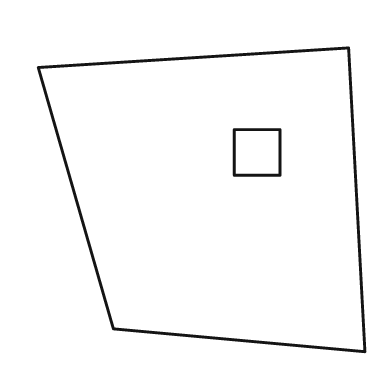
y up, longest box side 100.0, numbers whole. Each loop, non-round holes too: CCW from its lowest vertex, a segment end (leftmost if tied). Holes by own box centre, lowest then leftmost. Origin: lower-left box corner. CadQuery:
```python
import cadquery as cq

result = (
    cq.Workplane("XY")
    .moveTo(100.0, 0.0)
    .lineTo(95.0, 93.0)
    .lineTo(0.0, 87.0)
    .lineTo(23.0, 7.0)
    .close()
    .moveTo(60.0, 54.0)
    .lineTo(74.0, 54.0)
    .lineTo(74.0, 68.0)
    .lineTo(60.0, 68.0)
    .close()
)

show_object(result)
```